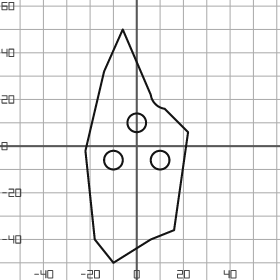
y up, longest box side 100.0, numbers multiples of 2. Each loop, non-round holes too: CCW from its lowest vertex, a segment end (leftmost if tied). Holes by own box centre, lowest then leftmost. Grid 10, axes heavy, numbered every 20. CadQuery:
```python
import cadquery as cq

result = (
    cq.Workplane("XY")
    .moveTo(-10.0, -50.0)
    .lineTo(6.0, -40.0)
    .lineTo(16.0, -36.0)
    .lineTo(22.0, 6.0)
    .lineTo(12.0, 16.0)
    .threePointArc((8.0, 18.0), (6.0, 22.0))
    .lineTo(-6.0, 50.0)
    .lineTo(-14.0, 32.0)
    .lineTo(-22.0, -2.0)
    .lineTo(-18.0, -40.0)
    .close()
    .moveTo(-10.0, -6.0)
    .circle(4.0)
    .moveTo(10.0, -6.0)
    .circle(4.0)
    .moveTo(0.0, 10.0)
    .circle(4.0)
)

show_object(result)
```